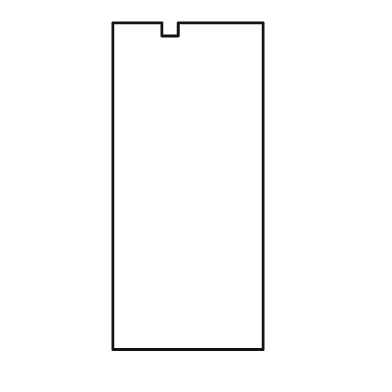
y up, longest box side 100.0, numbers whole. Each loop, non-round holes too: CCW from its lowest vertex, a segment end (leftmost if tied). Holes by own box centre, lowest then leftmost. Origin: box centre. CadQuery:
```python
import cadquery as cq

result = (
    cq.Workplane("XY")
    .moveTo(-23.0, -50.0)
    .lineTo(23.0, -50.0)
    .lineTo(23.0, 50.0)
    .lineTo(-3.0, 50.0)
    .lineTo(-3.0, 46.0)
    .lineTo(-8.0, 46.0)
    .lineTo(-8.0, 50.0)
    .lineTo(-23.0, 50.0)
    .close()
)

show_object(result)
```